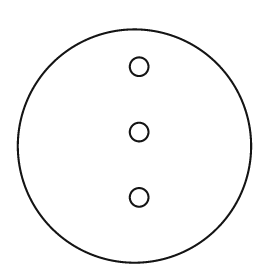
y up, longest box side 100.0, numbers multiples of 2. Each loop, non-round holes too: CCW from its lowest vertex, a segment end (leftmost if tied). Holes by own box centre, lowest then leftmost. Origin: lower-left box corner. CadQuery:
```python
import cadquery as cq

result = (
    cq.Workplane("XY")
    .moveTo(50.0, 50.0)
    .circle(50.0)
    .moveTo(52.0, 28.0)
    .circle(4.0)
    .moveTo(52.0, 56.0)
    .circle(4.0)
    .moveTo(52.0, 84.0)
    .circle(4.0)
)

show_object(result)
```